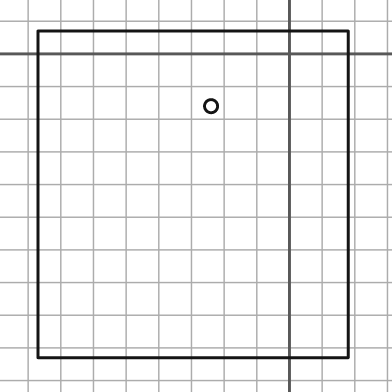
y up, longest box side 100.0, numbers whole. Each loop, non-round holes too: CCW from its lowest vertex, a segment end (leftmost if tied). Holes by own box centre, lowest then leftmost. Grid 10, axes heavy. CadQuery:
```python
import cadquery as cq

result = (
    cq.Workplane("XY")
    .moveTo(-77.0, -93.0)
    .lineTo(18.0, -93.0)
    .lineTo(18.0, 7.0)
    .lineTo(-77.0, 7.0)
    .close()
    .moveTo(-24.0, -16.0)
    .circle(2.0)
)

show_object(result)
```